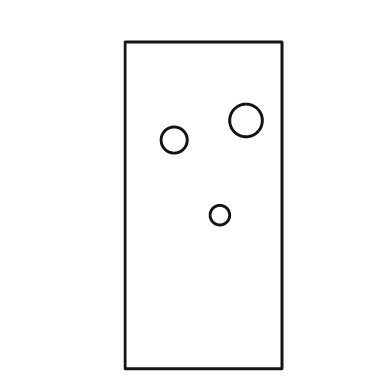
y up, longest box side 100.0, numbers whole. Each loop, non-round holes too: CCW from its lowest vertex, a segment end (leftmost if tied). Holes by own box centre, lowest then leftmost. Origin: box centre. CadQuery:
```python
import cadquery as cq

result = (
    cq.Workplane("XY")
    .moveTo(-24.0, -50.0)
    .lineTo(24.0, -50.0)
    .lineTo(24.0, 50.0)
    .lineTo(-24.0, 50.0)
    .close()
    .moveTo(5.0, -3.0)
    .circle(3.0)
    .moveTo(-9.0, 20.0)
    .circle(4.0)
    .moveTo(13.0, 26.0)
    .circle(5.0)
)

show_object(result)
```